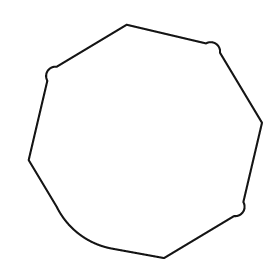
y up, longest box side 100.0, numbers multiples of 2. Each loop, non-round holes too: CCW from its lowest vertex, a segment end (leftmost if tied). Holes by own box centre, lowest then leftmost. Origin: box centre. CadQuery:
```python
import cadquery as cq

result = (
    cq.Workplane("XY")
    .moveTo(8.0, -50.0)
    .lineTo(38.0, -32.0)
    .threePointArc((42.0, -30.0), (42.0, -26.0))
    .lineTo(50.0, 8.0)
    .lineTo(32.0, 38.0)
    .threePointArc((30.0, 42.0), (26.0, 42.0))
    .lineTo(-8.0, 50.0)
    .lineTo(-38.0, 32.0)
    .threePointArc((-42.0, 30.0), (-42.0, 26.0))
    .lineTo(-50.0, -8.0)
    .lineTo(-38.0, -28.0)
    .threePointArc((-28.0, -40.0), (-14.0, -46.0))
    .close()
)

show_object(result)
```